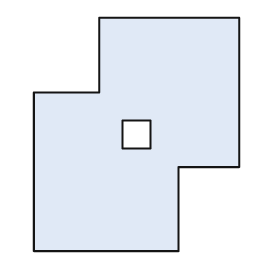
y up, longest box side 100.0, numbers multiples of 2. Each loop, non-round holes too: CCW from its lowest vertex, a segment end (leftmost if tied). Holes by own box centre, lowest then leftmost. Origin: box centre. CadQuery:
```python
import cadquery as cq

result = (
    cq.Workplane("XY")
    .moveTo(-44.0, -50.0)
    .lineTo(18.0, -50.0)
    .lineTo(18.0, -14.0)
    .lineTo(44.0, -14.0)
    .lineTo(44.0, 50.0)
    .lineTo(-16.0, 50.0)
    .lineTo(-16.0, 18.0)
    .lineTo(-44.0, 18.0)
    .close()
    .moveTo(-6.0, -6.0)
    .lineTo(6.0, -6.0)
    .lineTo(6.0, 6.0)
    .lineTo(-6.0, 6.0)
    .close()
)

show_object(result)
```